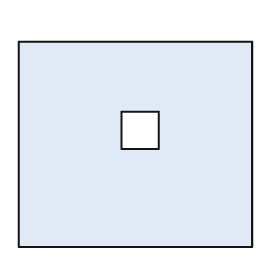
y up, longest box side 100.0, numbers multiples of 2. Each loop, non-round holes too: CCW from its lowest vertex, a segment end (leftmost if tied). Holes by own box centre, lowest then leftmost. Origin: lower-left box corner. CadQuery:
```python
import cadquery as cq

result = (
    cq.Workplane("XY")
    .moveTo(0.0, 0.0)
    .lineTo(100.0, 0.0)
    .lineTo(100.0, 88.0)
    .lineTo(0.0, 88.0)
    .close()
    .moveTo(44.0, 42.0)
    .lineTo(60.0, 42.0)
    .lineTo(60.0, 58.0)
    .lineTo(44.0, 58.0)
    .close()
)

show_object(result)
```